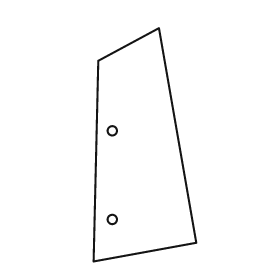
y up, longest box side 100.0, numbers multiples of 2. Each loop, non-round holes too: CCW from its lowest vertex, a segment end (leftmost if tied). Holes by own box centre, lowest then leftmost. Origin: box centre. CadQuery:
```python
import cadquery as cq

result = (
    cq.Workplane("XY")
    .moveTo(-22.0, -50.0)
    .lineTo(22.0, -42.0)
    .lineTo(6.0, 50.0)
    .lineTo(-20.0, 36.0)
    .close()
    .moveTo(-14.0, -32.0)
    .circle(2.0)
    .moveTo(-14.0, 6.0)
    .circle(2.0)
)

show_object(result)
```